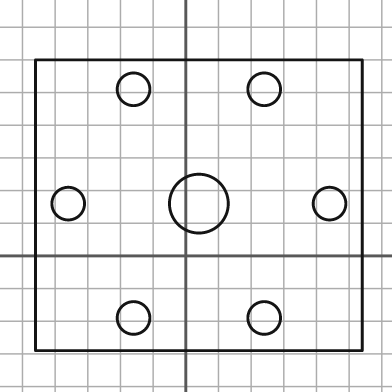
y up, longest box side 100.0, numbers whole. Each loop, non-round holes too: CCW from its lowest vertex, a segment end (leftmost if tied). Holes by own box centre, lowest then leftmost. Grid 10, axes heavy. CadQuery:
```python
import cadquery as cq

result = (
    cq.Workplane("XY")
    .moveTo(-46.0, -29.0)
    .lineTo(54.0, -29.0)
    .lineTo(54.0, 60.0)
    .lineTo(-46.0, 60.0)
    .close()
    .moveTo(-16.0, -19.0)
    .circle(5.0)
    .moveTo(24.0, -19.0)
    .circle(5.0)
    .moveTo(-36.0, 16.0)
    .circle(5.0)
    .moveTo(4.0, 16.0)
    .circle(9.0)
    .moveTo(44.0, 16.0)
    .circle(5.0)
    .moveTo(-16.0, 51.0)
    .circle(5.0)
    .moveTo(24.0, 51.0)
    .circle(5.0)
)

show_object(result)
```